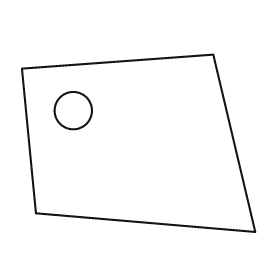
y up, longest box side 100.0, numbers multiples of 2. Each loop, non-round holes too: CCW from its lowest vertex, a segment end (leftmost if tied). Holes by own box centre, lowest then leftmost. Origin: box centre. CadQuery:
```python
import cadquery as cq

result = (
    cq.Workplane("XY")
    .moveTo(50.0, -38.0)
    .lineTo(32.0, 38.0)
    .lineTo(-50.0, 32.0)
    .lineTo(-44.0, -30.0)
    .close()
    .moveTo(-28.0, 14.0)
    .circle(8.0)
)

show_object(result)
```